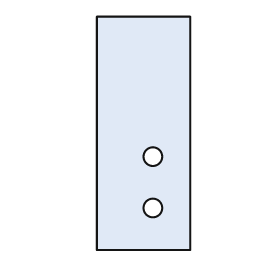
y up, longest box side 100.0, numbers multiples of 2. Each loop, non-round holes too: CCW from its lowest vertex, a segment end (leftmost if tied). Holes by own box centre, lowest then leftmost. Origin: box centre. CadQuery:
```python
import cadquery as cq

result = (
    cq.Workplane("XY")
    .moveTo(-20.0, -50.0)
    .lineTo(20.0, -50.0)
    .lineTo(20.0, 50.0)
    .lineTo(-20.0, 50.0)
    .close()
    .moveTo(4.0, -32.0)
    .circle(4.0)
    .moveTo(4.0, -10.0)
    .circle(4.0)
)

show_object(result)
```